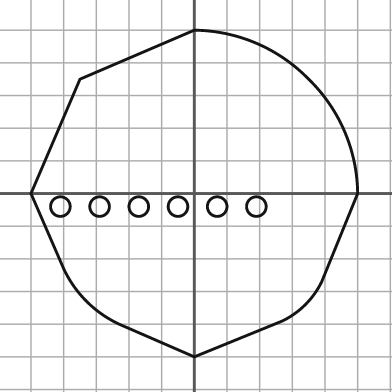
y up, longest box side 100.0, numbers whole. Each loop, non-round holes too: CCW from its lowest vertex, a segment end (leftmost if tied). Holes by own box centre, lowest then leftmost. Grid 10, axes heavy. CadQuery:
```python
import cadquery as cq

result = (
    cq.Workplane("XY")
    .moveTo(0.0, -50.0)
    .lineTo(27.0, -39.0)
    .threePointArc((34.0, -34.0), (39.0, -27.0))
    .lineTo(50.0, 0.0)
    .threePointArc((46.0, 19.0), (35.0, 35.0))
    .threePointArc((19.0, 46.0), (0.0, 50.0))
    .lineTo(-35.0, 35.0)
    .lineTo(-50.0, 0.0)
    .lineTo(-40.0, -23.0)
    .threePointArc((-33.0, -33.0), (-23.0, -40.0))
    .close()
    .moveTo(-41.0, -4.0)
    .circle(3.0)
    .moveTo(-29.0, -4.0)
    .circle(3.0)
    .moveTo(-17.0, -4.0)
    .circle(3.0)
    .moveTo(-5.0, -4.0)
    .circle(3.0)
    .moveTo(7.0, -4.0)
    .circle(3.0)
    .moveTo(19.0, -4.0)
    .circle(3.0)
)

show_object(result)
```